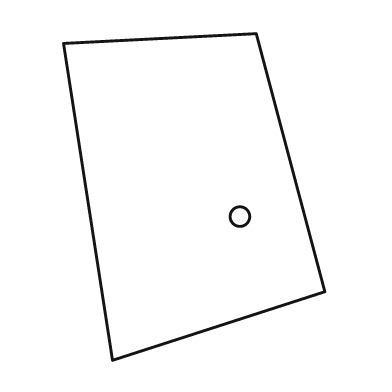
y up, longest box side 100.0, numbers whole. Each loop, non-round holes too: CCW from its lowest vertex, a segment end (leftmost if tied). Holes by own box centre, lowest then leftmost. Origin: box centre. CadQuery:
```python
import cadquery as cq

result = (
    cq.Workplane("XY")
    .moveTo(-25.0, -50.0)
    .lineTo(40.0, -29.0)
    .lineTo(19.0, 50.0)
    .lineTo(-40.0, 47.0)
    .close()
    .moveTo(14.0, -6.0)
    .circle(3.0)
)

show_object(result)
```